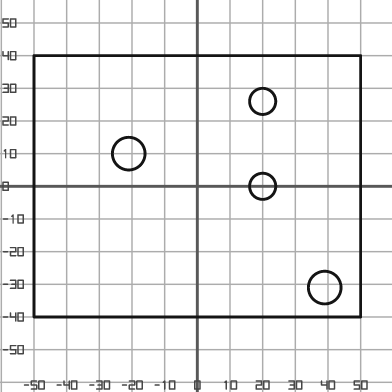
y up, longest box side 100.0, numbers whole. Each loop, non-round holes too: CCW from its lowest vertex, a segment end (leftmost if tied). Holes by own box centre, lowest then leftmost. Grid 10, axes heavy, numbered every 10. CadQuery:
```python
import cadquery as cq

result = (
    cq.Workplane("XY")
    .moveTo(-50.0, -40.0)
    .lineTo(50.0, -40.0)
    .lineTo(50.0, 40.0)
    .lineTo(-50.0, 40.0)
    .close()
    .moveTo(39.0, -31.0)
    .circle(5.0)
    .moveTo(20.0, 0.0)
    .circle(4.0)
    .moveTo(-21.0, 10.0)
    .circle(5.0)
    .moveTo(20.0, 26.0)
    .circle(4.0)
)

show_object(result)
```